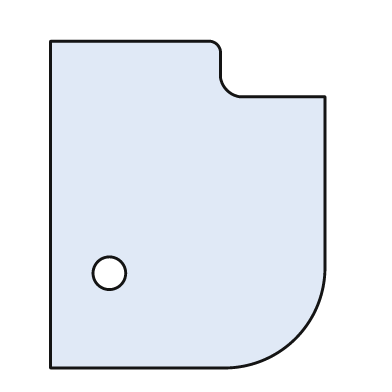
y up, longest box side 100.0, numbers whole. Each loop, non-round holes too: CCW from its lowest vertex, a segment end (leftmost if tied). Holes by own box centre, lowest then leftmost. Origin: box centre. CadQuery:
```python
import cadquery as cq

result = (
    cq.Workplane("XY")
    .moveTo(-42.0, -50.0)
    .lineTo(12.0, -50.0)
    .threePointArc((33.0, -41.0), (42.0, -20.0))
    .lineTo(42.0, 33.0)
    .lineTo(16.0, 33.0)
    .threePointArc((12.0, 35.0), (10.0, 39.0))
    .lineTo(10.0, 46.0)
    .threePointArc((9.0, 49.0), (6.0, 50.0))
    .lineTo(-42.0, 50.0)
    .close()
    .moveTo(-24.0, -21.0)
    .circle(5.0)
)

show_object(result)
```